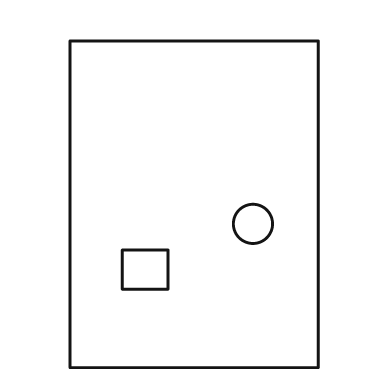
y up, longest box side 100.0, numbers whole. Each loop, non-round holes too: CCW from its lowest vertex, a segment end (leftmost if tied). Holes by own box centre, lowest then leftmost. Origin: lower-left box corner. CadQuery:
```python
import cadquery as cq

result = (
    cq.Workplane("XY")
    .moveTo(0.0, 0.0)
    .lineTo(76.0, 0.0)
    .lineTo(76.0, 100.0)
    .lineTo(0.0, 100.0)
    .close()
    .moveTo(16.0, 24.0)
    .lineTo(30.0, 24.0)
    .lineTo(30.0, 36.0)
    .lineTo(16.0, 36.0)
    .close()
    .moveTo(56.0, 44.0)
    .circle(6.0)
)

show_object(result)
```